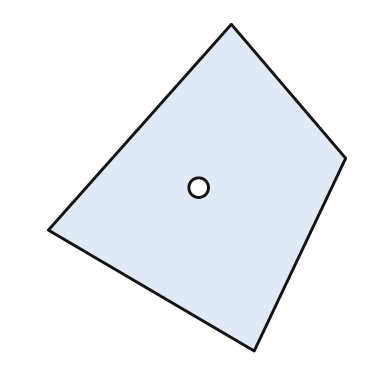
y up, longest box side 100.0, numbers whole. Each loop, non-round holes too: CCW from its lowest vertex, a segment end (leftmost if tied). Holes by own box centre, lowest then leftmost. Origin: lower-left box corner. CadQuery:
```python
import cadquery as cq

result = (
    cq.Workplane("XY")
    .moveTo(63.0, 0.0)
    .lineTo(91.0, 59.0)
    .lineTo(56.0, 100.0)
    .lineTo(0.0, 37.0)
    .close()
    .moveTo(46.0, 50.0)
    .circle(3.0)
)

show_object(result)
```